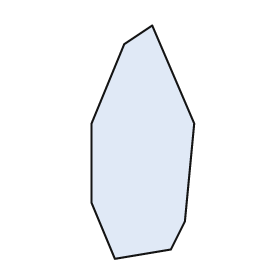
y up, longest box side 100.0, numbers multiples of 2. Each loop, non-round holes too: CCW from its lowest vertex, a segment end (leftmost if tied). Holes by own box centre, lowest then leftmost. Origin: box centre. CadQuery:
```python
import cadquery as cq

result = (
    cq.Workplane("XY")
    .moveTo(-12.0, -50.0)
    .lineTo(12.0, -46.0)
    .lineTo(18.0, -34.0)
    .lineTo(22.0, 8.0)
    .lineTo(4.0, 50.0)
    .lineTo(-8.0, 42.0)
    .lineTo(-22.0, 8.0)
    .lineTo(-22.0, -26.0)
    .close()
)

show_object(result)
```